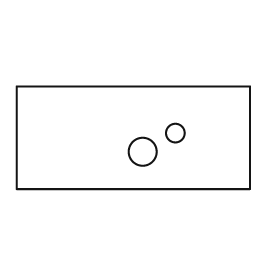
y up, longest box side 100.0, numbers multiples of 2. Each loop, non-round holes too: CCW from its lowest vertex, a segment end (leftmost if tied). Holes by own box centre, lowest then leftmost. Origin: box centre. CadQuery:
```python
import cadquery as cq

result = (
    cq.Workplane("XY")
    .moveTo(-50.0, -22.0)
    .lineTo(50.0, -22.0)
    .lineTo(50.0, 22.0)
    .lineTo(-50.0, 22.0)
    .close()
    .moveTo(4.0, -6.0)
    .circle(6.0)
    .moveTo(18.0, 2.0)
    .circle(4.0)
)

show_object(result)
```